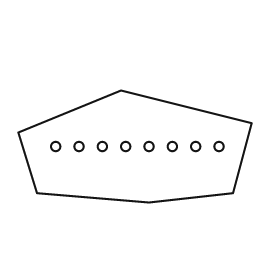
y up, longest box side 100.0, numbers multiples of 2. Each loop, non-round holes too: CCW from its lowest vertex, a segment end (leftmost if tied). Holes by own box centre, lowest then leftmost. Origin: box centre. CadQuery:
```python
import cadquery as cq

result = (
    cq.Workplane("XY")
    .moveTo(6.0, -24.0)
    .lineTo(42.0, -20.0)
    .lineTo(50.0, 10.0)
    .lineTo(-6.0, 24.0)
    .lineTo(-50.0, 6.0)
    .lineTo(-42.0, -20.0)
    .close()
    .moveTo(-34.0, 0.0)
    .circle(2.0)
    .moveTo(-24.0, 0.0)
    .circle(2.0)
    .moveTo(-14.0, 0.0)
    .circle(2.0)
    .moveTo(-4.0, 0.0)
    .circle(2.0)
    .moveTo(6.0, 0.0)
    .circle(2.0)
    .moveTo(16.0, 0.0)
    .circle(2.0)
    .moveTo(26.0, 0.0)
    .circle(2.0)
    .moveTo(36.0, 0.0)
    .circle(2.0)
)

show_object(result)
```